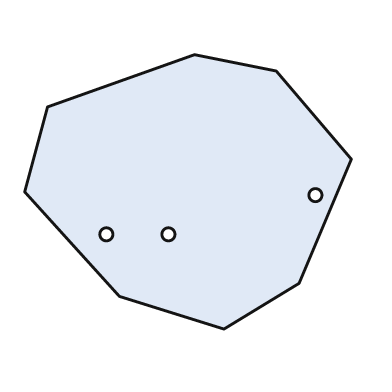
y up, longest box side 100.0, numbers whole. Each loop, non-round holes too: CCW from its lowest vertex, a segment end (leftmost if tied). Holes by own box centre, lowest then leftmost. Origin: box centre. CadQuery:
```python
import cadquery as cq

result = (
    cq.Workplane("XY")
    .moveTo(11.0, -42.0)
    .lineTo(34.0, -28.0)
    .lineTo(50.0, 10.0)
    .lineTo(27.0, 37.0)
    .lineTo(2.0, 42.0)
    .lineTo(-43.0, 26.0)
    .lineTo(-50.0, 0.0)
    .lineTo(-21.0, -32.0)
    .close()
    .moveTo(-25.0, -13.0)
    .circle(2.0)
    .moveTo(-6.0, -13.0)
    .circle(2.0)
    .moveTo(39.0, -1.0)
    .circle(2.0)
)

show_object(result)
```